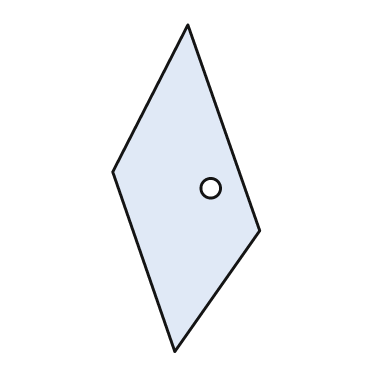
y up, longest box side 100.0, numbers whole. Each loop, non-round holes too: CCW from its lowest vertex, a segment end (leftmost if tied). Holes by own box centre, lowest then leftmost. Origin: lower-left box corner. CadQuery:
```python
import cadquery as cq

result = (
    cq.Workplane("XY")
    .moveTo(19.0, 0.0)
    .lineTo(45.0, 37.0)
    .lineTo(23.0, 100.0)
    .lineTo(0.0, 55.0)
    .close()
    .moveTo(30.0, 50.0)
    .circle(3.0)
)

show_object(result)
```